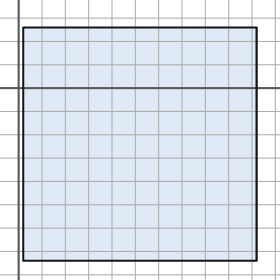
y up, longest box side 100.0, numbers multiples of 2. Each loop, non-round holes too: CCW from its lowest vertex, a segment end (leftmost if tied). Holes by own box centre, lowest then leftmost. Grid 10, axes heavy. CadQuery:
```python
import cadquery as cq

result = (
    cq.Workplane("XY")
    .moveTo(2.0, -74.0)
    .lineTo(102.0, -74.0)
    .lineTo(102.0, 26.0)
    .lineTo(2.0, 26.0)
    .close()
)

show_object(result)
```